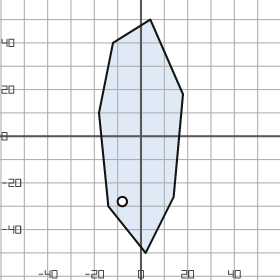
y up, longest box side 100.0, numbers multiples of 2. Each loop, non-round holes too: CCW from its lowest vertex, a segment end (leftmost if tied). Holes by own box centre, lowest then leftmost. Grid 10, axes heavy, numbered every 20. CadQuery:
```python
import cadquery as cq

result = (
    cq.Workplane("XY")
    .moveTo(2.0, -50.0)
    .lineTo(14.0, -26.0)
    .lineTo(18.0, 18.0)
    .lineTo(4.0, 50.0)
    .lineTo(-12.0, 40.0)
    .lineTo(-18.0, 10.0)
    .lineTo(-14.0, -30.0)
    .close()
    .moveTo(-8.0, -28.0)
    .circle(2.0)
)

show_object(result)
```